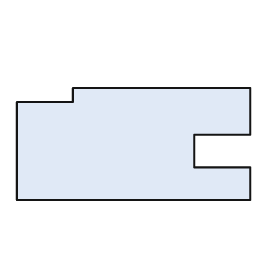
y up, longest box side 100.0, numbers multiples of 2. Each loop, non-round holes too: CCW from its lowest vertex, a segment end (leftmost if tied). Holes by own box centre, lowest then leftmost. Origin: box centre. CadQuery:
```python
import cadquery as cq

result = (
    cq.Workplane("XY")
    .moveTo(-50.0, -24.0)
    .lineTo(50.0, -24.0)
    .lineTo(50.0, -10.0)
    .lineTo(26.0, -10.0)
    .lineTo(26.0, 4.0)
    .lineTo(50.0, 4.0)
    .lineTo(50.0, 24.0)
    .lineTo(-26.0, 24.0)
    .lineTo(-26.0, 18.0)
    .lineTo(-50.0, 18.0)
    .close()
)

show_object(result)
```